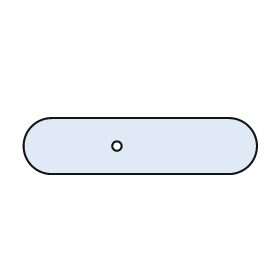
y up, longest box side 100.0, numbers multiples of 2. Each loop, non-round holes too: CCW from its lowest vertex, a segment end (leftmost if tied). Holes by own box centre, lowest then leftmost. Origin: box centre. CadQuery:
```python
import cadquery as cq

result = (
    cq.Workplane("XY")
    .moveTo(-38.0, -12.0)
    .lineTo(38.0, -12.0)
    .threePointArc((50.0, 0.0), (38.0, 12.0))
    .lineTo(-38.0, 12.0)
    .threePointArc((-50.0, 0.0), (-38.0, -12.0))
    .close()
    .moveTo(-10.0, 0.0)
    .circle(2.0)
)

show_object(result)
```